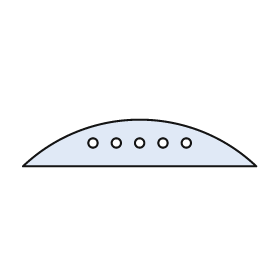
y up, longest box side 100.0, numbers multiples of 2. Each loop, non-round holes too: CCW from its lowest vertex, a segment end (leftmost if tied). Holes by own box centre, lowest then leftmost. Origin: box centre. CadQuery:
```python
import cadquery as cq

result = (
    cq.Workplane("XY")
    .moveTo(-50.0, -10.0)
    .lineTo(50.0, -10.0)
    .threePointArc((0.0, 10.0), (-50.0, -10.0))
    .close()
    .moveTo(-20.0, 0.0)
    .circle(2.0)
    .moveTo(-10.0, 0.0)
    .circle(2.0)
    .moveTo(0.0, 0.0)
    .circle(2.0)
    .moveTo(10.0, 0.0)
    .circle(2.0)
    .moveTo(20.0, 0.0)
    .circle(2.0)
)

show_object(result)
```